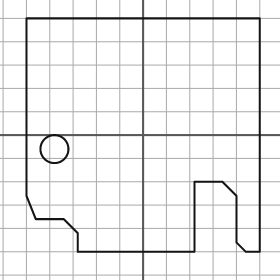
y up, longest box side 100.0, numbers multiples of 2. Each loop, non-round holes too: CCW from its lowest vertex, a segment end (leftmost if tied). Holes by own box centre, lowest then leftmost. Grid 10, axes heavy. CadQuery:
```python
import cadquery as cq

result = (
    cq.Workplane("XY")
    .moveTo(-28.0, -50.0)
    .lineTo(22.0, -50.0)
    .lineTo(22.0, -20.0)
    .lineTo(34.0, -20.0)
    .lineTo(40.0, -26.0)
    .lineTo(40.0, -46.0)
    .lineTo(44.0, -50.0)
    .lineTo(50.0, -50.0)
    .lineTo(50.0, 50.0)
    .lineTo(-50.0, 50.0)
    .lineTo(-50.0, -26.0)
    .lineTo(-46.0, -36.0)
    .lineTo(-34.0, -36.0)
    .lineTo(-28.0, -42.0)
    .close()
    .moveTo(-38.0, -6.0)
    .circle(6.0)
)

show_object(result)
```